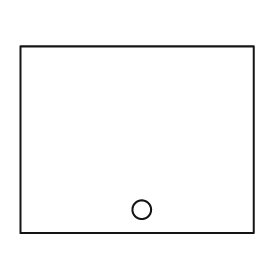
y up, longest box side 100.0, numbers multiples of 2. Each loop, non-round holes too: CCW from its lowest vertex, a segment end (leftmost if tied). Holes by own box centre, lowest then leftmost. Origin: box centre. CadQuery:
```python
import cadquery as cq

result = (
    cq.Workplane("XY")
    .moveTo(-50.0, -40.0)
    .lineTo(50.0, -40.0)
    .lineTo(50.0, 40.0)
    .lineTo(-50.0, 40.0)
    .close()
    .moveTo(2.0, -30.0)
    .circle(4.0)
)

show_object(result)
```